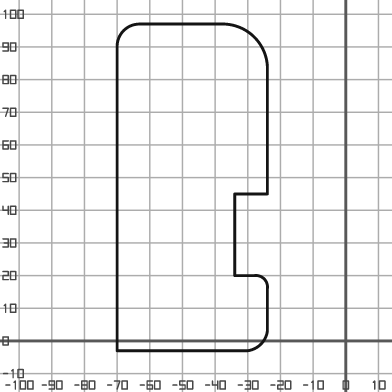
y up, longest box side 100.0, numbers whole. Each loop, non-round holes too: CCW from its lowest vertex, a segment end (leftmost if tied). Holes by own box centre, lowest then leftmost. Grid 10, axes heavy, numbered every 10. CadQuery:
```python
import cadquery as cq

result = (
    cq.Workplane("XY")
    .moveTo(-70.0, -3.0)
    .lineTo(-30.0, -3.0)
    .threePointArc((-26.0, -1.0), (-24.0, 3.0))
    .lineTo(-24.0, 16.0)
    .threePointArc((-25.0, 19.0), (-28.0, 20.0))
    .lineTo(-34.0, 20.0)
    .lineTo(-34.0, 45.0)
    .lineTo(-24.0, 45.0)
    .lineTo(-24.0, 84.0)
    .threePointArc((-28.0, 93.0), (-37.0, 97.0))
    .lineTo(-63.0, 97.0)
    .threePointArc((-68.0, 95.0), (-70.0, 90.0))
    .close()
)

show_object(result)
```